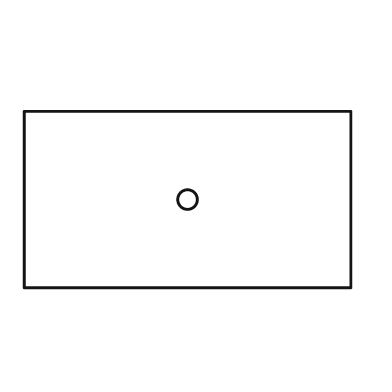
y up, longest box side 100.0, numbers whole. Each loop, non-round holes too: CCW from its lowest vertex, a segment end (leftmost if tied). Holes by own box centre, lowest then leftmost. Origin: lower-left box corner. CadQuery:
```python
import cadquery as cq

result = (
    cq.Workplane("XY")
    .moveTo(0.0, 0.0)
    .lineTo(100.0, 0.0)
    .lineTo(100.0, 54.0)
    .lineTo(0.0, 54.0)
    .close()
    .moveTo(50.0, 27.0)
    .circle(3.0)
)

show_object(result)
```